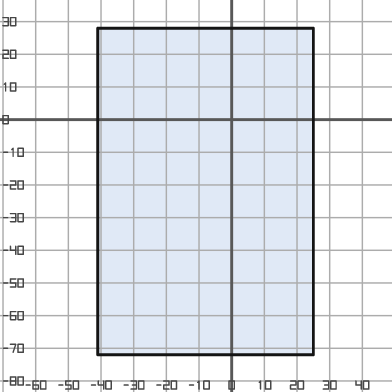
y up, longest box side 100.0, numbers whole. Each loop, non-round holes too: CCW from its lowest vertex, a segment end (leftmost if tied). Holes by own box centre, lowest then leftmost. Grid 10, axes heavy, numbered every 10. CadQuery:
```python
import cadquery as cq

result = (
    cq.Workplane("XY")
    .moveTo(-41.0, -72.0)
    .lineTo(25.0, -72.0)
    .lineTo(25.0, 28.0)
    .lineTo(-41.0, 28.0)
    .close()
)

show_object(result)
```